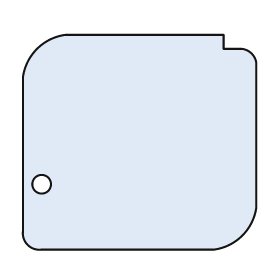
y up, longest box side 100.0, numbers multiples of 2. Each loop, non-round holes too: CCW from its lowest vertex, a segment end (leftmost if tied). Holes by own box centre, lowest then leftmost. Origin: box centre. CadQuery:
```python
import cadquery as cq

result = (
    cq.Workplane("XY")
    .moveTo(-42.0, -46.0)
    .lineTo(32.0, -46.0)
    .threePointArc((44.0, -40.0), (50.0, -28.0))
    .lineTo(50.0, 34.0)
    .threePointArc((48.0, 38.0), (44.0, 40.0))
    .lineTo(36.0, 40.0)
    .lineTo(36.0, 46.0)
    .lineTo(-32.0, 46.0)
    .threePointArc((-44.0, 40.0), (-50.0, 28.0))
    .lineTo(-50.0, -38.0)
    .threePointArc((-48.0, -44.0), (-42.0, -46.0))
    .close()
    .moveTo(-42.0, -18.0)
    .circle(4.0)
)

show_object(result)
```